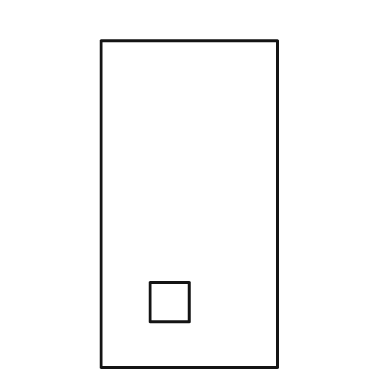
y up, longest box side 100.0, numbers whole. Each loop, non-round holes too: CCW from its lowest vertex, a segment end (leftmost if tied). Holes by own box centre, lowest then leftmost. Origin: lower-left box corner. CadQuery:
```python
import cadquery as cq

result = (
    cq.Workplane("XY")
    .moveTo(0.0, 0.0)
    .lineTo(54.0, 0.0)
    .lineTo(54.0, 100.0)
    .lineTo(0.0, 100.0)
    .close()
    .moveTo(15.0, 14.0)
    .lineTo(27.0, 14.0)
    .lineTo(27.0, 26.0)
    .lineTo(15.0, 26.0)
    .close()
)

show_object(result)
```